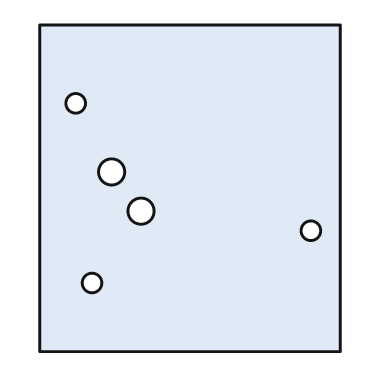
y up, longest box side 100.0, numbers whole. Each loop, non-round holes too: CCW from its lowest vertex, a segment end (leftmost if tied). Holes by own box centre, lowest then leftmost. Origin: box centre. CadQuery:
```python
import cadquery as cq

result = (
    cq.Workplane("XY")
    .moveTo(-46.0, -50.0)
    .lineTo(46.0, -50.0)
    .lineTo(46.0, 50.0)
    .lineTo(-46.0, 50.0)
    .close()
    .moveTo(-30.0, -29.0)
    .circle(3.0)
    .moveTo(37.0, -13.0)
    .circle(3.0)
    .moveTo(-15.0, -7.0)
    .circle(4.0)
    .moveTo(-24.0, 5.0)
    .circle(4.0)
    .moveTo(-35.0, 26.0)
    .circle(3.0)
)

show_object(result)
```